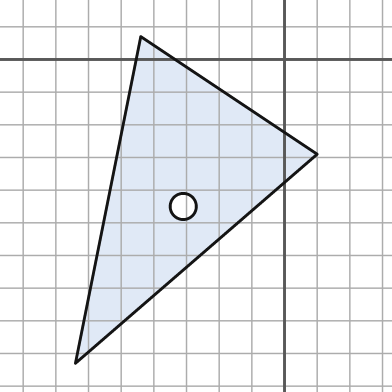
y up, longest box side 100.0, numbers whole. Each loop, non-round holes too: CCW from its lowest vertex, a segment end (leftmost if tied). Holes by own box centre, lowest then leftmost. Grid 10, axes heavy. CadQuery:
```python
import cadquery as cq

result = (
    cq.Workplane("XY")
    .moveTo(-64.0, -93.0)
    .lineTo(10.0, -29.0)
    .lineTo(-44.0, 7.0)
    .close()
    .moveTo(-31.0, -45.0)
    .circle(4.0)
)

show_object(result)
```